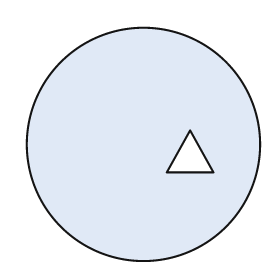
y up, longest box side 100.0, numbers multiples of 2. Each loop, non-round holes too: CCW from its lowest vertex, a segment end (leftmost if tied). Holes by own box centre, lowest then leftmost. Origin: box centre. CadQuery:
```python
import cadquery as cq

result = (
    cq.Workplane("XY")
    .moveTo(0.0, 0.0)
    .circle(50.0)
    .moveTo(10.0, -12.0)
    .lineTo(30.0, -12.0)
    .lineTo(20.0, 6.0)
    .close()
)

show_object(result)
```